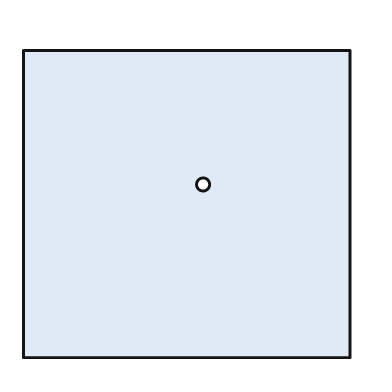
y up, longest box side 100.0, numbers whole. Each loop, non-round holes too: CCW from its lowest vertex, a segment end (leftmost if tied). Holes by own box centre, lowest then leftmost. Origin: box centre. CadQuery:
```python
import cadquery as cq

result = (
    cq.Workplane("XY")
    .moveTo(-50.0, -47.0)
    .lineTo(50.0, -47.0)
    .lineTo(50.0, 47.0)
    .lineTo(-50.0, 47.0)
    .close()
    .moveTo(5.0, 6.0)
    .circle(2.0)
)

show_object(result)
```